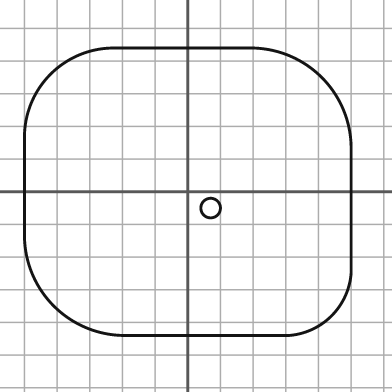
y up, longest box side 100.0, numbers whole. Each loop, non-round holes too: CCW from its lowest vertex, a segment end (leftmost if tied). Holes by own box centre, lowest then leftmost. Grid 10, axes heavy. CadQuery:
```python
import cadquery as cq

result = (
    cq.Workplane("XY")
    .moveTo(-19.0, -44.0)
    .lineTo(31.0, -44.0)
    .threePointArc((44.0, -38.0), (50.0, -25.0))
    .lineTo(50.0, 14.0)
    .threePointArc((41.0, 35.0), (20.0, 44.0))
    .lineTo(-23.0, 44.0)
    .threePointArc((-42.0, 36.0), (-50.0, 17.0))
    .lineTo(-50.0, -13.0)
    .threePointArc((-41.0, -35.0), (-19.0, -44.0))
    .close()
    .moveTo(7.0, -5.0)
    .circle(3.0)
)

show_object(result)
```